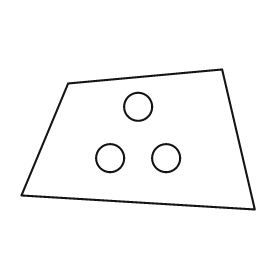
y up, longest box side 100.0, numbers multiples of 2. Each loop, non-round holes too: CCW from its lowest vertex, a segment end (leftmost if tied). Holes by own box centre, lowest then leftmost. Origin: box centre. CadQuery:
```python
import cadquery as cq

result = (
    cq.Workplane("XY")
    .moveTo(50.0, -30.0)
    .lineTo(36.0, 30.0)
    .lineTo(-30.0, 24.0)
    .lineTo(-50.0, -24.0)
    .close()
    .moveTo(-12.0, -8.0)
    .circle(6.0)
    .moveTo(12.0, -8.0)
    .circle(6.0)
    .moveTo(0.0, 14.0)
    .circle(6.0)
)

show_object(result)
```